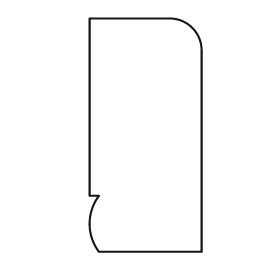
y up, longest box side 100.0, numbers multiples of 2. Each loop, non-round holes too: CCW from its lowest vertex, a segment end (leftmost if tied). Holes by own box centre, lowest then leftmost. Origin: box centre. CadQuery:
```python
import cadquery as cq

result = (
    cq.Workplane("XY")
    .moveTo(-20.0, -50.0)
    .lineTo(24.0, -50.0)
    .lineTo(24.0, 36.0)
    .threePointArc((20.0, 46.0), (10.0, 50.0))
    .lineTo(-24.0, 50.0)
    .lineTo(-24.0, -26.0)
    .lineTo(-20.0, -26.0)
    .threePointArc((-24.0, -38.0), (-20.0, -50.0))
    .close()
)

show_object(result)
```